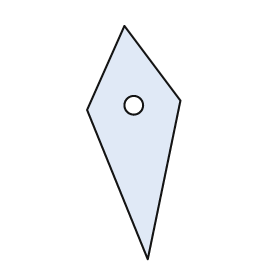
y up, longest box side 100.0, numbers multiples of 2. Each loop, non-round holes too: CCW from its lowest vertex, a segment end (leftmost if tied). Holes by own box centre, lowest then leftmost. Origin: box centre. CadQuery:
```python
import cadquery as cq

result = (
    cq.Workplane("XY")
    .moveTo(6.0, -50.0)
    .lineTo(20.0, 18.0)
    .lineTo(-4.0, 50.0)
    .lineTo(-20.0, 14.0)
    .close()
    .moveTo(0.0, 16.0)
    .circle(4.0)
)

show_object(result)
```